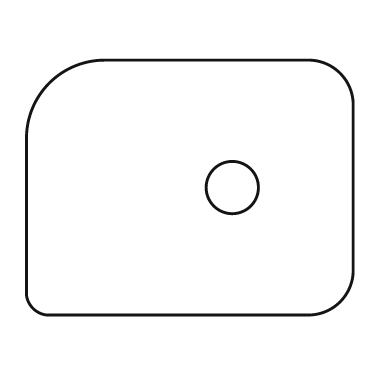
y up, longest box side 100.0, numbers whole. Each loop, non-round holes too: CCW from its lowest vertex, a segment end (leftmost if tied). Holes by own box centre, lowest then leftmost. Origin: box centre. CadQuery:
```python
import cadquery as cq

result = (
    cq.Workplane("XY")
    .moveTo(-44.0, -39.0)
    .lineTo(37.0, -39.0)
    .threePointArc((46.0, -35.0), (50.0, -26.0))
    .lineTo(50.0, 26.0)
    .threePointArc((46.0, 35.0), (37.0, 39.0))
    .lineTo(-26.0, 39.0)
    .threePointArc((-43.0, 32.0), (-50.0, 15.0))
    .lineTo(-50.0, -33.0)
    .threePointArc((-48.0, -37.0), (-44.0, -39.0))
    .close()
    .moveTo(13.0, 0.0)
    .circle(8.0)
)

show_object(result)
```